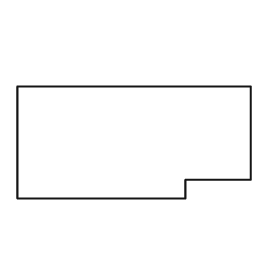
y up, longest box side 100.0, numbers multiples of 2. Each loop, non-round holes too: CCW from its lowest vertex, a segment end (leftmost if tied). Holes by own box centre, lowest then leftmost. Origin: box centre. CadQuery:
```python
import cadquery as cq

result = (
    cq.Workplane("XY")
    .moveTo(-50.0, -24.0)
    .lineTo(22.0, -24.0)
    .lineTo(22.0, -16.0)
    .lineTo(50.0, -16.0)
    .lineTo(50.0, 24.0)
    .lineTo(-50.0, 24.0)
    .close()
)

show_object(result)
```